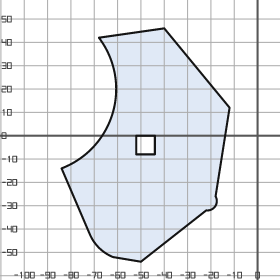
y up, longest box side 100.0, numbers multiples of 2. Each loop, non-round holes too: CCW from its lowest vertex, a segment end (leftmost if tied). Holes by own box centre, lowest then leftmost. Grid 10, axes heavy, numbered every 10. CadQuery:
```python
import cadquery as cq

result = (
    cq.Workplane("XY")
    .moveTo(-50.0, -54.0)
    .lineTo(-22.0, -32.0)
    .threePointArc((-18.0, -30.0), (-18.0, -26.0))
    .lineTo(-12.0, 12.0)
    .lineTo(-40.0, 46.0)
    .lineTo(-68.0, 42.0)
    .threePointArc((-62.0, 10.0), (-84.0, -14.0))
    .lineTo(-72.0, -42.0)
    .threePointArc((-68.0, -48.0), (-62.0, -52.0))
    .close()
    .moveTo(-52.0, -8.0)
    .lineTo(-44.0, -8.0)
    .lineTo(-44.0, 0.0)
    .lineTo(-52.0, 0.0)
    .close()
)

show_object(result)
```